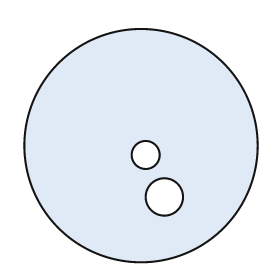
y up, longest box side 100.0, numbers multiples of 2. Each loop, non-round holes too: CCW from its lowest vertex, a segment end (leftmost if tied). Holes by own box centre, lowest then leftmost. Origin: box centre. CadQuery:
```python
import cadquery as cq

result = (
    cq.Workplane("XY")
    .moveTo(0.0, 0.0)
    .circle(50.0)
    .moveTo(10.0, -22.0)
    .circle(8.0)
    .moveTo(2.0, -4.0)
    .circle(6.0)
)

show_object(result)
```